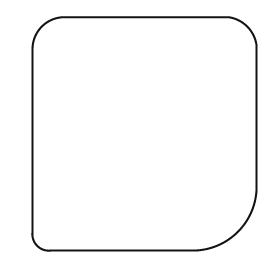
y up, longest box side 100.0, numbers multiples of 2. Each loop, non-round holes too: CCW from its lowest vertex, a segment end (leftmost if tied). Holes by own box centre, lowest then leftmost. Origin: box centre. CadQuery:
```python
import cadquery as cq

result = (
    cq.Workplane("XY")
    .moveTo(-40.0, -50.0)
    .lineTo(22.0, -50.0)
    .threePointArc((40.0, -42.0), (48.0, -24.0))
    .lineTo(48.0, 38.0)
    .threePointArc((44.0, 46.0), (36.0, 50.0))
    .lineTo(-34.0, 50.0)
    .threePointArc((-44.0, 46.0), (-48.0, 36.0))
    .lineTo(-48.0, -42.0)
    .threePointArc((-46.0, -48.0), (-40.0, -50.0))
    .close()
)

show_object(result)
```